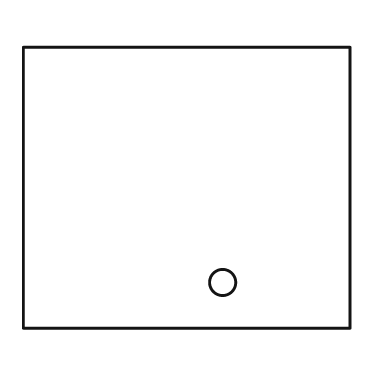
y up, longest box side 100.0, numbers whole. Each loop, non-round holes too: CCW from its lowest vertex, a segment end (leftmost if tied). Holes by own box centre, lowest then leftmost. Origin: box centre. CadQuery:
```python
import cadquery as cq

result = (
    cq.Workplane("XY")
    .moveTo(-50.0, -43.0)
    .lineTo(50.0, -43.0)
    .lineTo(50.0, 43.0)
    .lineTo(-50.0, 43.0)
    .close()
    .moveTo(11.0, -29.0)
    .circle(4.0)
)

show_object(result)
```